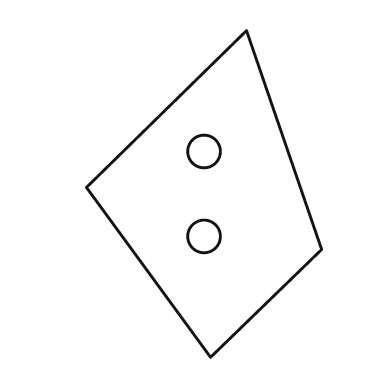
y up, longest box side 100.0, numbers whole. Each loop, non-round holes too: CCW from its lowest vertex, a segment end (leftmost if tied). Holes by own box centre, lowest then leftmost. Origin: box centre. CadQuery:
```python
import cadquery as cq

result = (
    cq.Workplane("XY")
    .moveTo(2.0, -50.0)
    .lineTo(36.0, -17.0)
    .lineTo(13.0, 50.0)
    .lineTo(-36.0, 2.0)
    .close()
    .moveTo(0.0, -13.0)
    .circle(5.0)
    .moveTo(0.0, 13.0)
    .circle(5.0)
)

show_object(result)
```